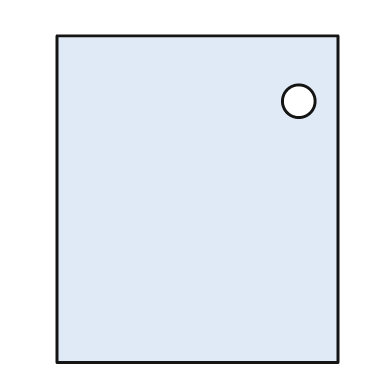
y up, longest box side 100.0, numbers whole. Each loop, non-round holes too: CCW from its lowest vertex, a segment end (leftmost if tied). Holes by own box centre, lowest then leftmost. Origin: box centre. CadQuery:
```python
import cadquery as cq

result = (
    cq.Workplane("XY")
    .moveTo(-43.0, -50.0)
    .lineTo(43.0, -50.0)
    .lineTo(43.0, 50.0)
    .lineTo(-43.0, 50.0)
    .close()
    .moveTo(31.0, 30.0)
    .circle(5.0)
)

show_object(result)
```